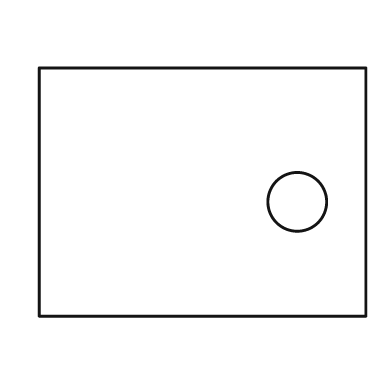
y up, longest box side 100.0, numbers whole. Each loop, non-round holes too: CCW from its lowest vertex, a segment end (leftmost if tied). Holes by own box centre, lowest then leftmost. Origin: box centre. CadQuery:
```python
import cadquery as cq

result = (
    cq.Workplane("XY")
    .moveTo(-50.0, -38.0)
    .lineTo(50.0, -38.0)
    .lineTo(50.0, 38.0)
    .lineTo(-50.0, 38.0)
    .close()
    .moveTo(29.0, -3.0)
    .circle(9.0)
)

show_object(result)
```